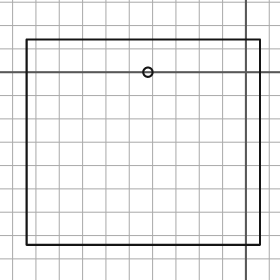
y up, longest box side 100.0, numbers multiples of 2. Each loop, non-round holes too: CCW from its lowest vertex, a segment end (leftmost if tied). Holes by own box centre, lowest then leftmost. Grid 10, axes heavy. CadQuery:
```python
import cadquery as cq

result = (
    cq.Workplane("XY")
    .moveTo(-94.0, -74.0)
    .lineTo(6.0, -74.0)
    .lineTo(6.0, 14.0)
    .lineTo(-94.0, 14.0)
    .close()
    .moveTo(-42.0, 0.0)
    .circle(2.0)
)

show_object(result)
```